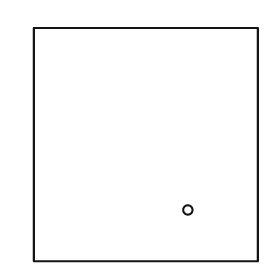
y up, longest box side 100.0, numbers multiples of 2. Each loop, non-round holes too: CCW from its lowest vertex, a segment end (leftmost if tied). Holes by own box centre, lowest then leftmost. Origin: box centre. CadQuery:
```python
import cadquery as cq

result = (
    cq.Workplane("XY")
    .moveTo(-48.0, -50.0)
    .lineTo(48.0, -50.0)
    .lineTo(48.0, 50.0)
    .lineTo(-48.0, 50.0)
    .close()
    .moveTo(18.0, -28.0)
    .circle(2.0)
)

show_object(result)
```